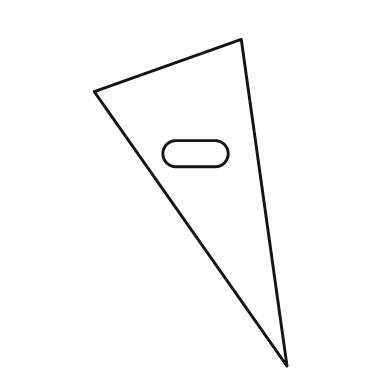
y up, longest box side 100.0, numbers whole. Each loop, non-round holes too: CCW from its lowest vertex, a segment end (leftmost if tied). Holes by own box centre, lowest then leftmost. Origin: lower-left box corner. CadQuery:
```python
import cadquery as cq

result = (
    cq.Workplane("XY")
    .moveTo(59.0, 0.0)
    .lineTo(45.0, 100.0)
    .lineTo(0.0, 84.0)
    .close()
    .moveTo(25.0, 61.0)
    .lineTo(37.0, 61.0)
    .threePointArc((41.0, 65.0), (37.0, 69.0))
    .lineTo(25.0, 69.0)
    .threePointArc((21.0, 65.0), (25.0, 61.0))
    .close()
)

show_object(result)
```